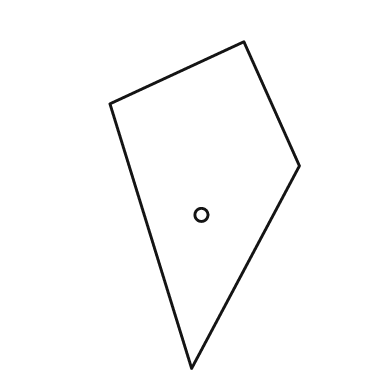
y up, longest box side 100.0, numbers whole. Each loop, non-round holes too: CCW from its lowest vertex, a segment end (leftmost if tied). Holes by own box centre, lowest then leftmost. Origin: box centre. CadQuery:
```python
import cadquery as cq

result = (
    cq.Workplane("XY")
    .moveTo(-4.0, -50.0)
    .lineTo(29.0, 12.0)
    .lineTo(12.0, 50.0)
    .lineTo(-29.0, 31.0)
    .close()
    .moveTo(-1.0, -3.0)
    .circle(2.0)
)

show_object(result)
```